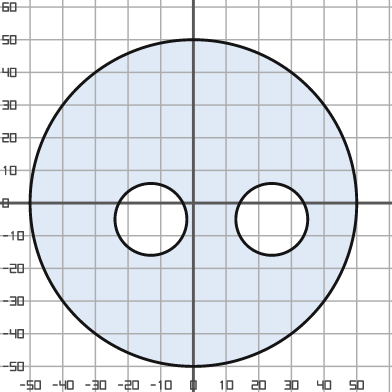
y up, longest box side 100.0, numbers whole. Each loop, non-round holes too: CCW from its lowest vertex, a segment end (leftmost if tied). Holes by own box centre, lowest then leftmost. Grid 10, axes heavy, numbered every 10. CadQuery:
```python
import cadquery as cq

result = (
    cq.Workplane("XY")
    .moveTo(0.0, 0.0)
    .circle(50.0)
    .moveTo(-13.0, -5.0)
    .circle(11.0)
    .moveTo(24.0, -5.0)
    .circle(11.0)
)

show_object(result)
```